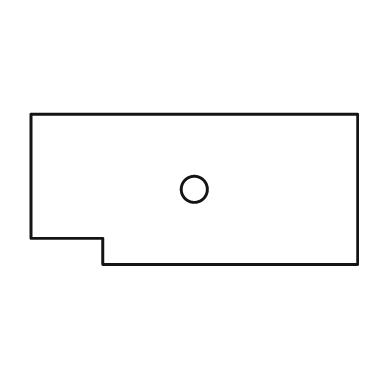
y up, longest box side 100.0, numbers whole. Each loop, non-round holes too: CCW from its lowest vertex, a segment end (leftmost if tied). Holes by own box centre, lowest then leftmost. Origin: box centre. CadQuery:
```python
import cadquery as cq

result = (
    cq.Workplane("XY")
    .moveTo(-28.0, -23.0)
    .lineTo(50.0, -23.0)
    .lineTo(50.0, 23.0)
    .lineTo(-50.0, 23.0)
    .lineTo(-50.0, -15.0)
    .lineTo(-28.0, -15.0)
    .close()
    .moveTo(0.0, 0.0)
    .circle(4.0)
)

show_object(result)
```